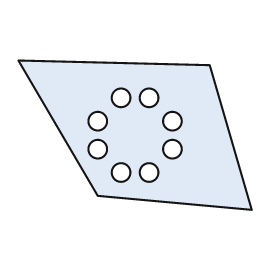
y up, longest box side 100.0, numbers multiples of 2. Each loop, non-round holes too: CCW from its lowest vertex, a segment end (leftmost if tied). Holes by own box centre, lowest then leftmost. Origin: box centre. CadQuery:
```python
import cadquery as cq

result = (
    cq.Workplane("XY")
    .moveTo(50.0, -32.0)
    .lineTo(32.0, 30.0)
    .lineTo(-50.0, 32.0)
    .lineTo(-16.0, -26.0)
    .close()
    .moveTo(-6.0, -16.0)
    .circle(4.0)
    .moveTo(6.0, -16.0)
    .circle(4.0)
    .moveTo(-16.0, -6.0)
    .circle(4.0)
    .moveTo(16.0, -6.0)
    .circle(4.0)
    .moveTo(-16.0, 6.0)
    .circle(4.0)
    .moveTo(16.0, 6.0)
    .circle(4.0)
    .moveTo(-6.0, 16.0)
    .circle(4.0)
    .moveTo(6.0, 16.0)
    .circle(4.0)
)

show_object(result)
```